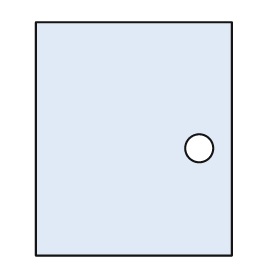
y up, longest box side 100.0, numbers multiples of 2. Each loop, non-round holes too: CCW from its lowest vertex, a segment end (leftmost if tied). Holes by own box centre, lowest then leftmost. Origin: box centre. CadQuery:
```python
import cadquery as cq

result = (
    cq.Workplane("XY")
    .moveTo(-42.0, -50.0)
    .lineTo(42.0, -50.0)
    .lineTo(42.0, 50.0)
    .lineTo(-42.0, 50.0)
    .close()
    .moveTo(28.0, -4.0)
    .circle(6.0)
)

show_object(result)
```